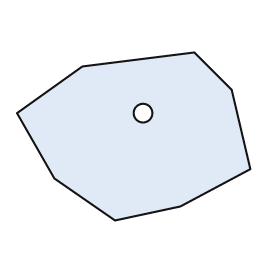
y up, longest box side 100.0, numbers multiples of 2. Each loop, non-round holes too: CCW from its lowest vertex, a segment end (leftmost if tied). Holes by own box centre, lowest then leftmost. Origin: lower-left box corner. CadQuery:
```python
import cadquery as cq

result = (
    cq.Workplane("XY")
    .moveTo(42.0, 0.0)
    .lineTo(70.0, 6.0)
    .lineTo(100.0, 22.0)
    .lineTo(92.0, 56.0)
    .lineTo(76.0, 72.0)
    .lineTo(28.0, 66.0)
    .lineTo(0.0, 46.0)
    .lineTo(16.0, 18.0)
    .close()
    .moveTo(54.0, 46.0)
    .circle(4.0)
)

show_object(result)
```